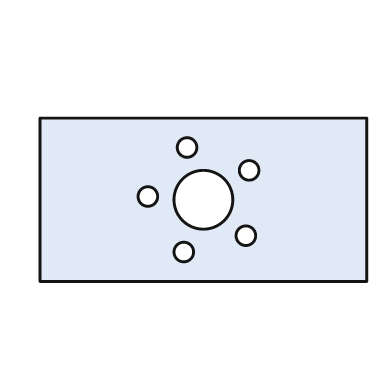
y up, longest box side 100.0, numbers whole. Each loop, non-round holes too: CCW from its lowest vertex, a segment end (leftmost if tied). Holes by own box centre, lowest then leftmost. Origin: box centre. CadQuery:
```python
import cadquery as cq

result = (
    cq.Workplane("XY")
    .moveTo(-50.0, -25.0)
    .lineTo(50.0, -25.0)
    .lineTo(50.0, 25.0)
    .lineTo(-50.0, 25.0)
    .close()
    .moveTo(-6.0, -16.0)
    .circle(3.0)
    .moveTo(13.0, -11.0)
    .circle(3.0)
    .moveTo(0.0, 0.0)
    .circle(9.0)
    .moveTo(-17.0, 1.0)
    .circle(3.0)
    .moveTo(14.0, 9.0)
    .circle(3.0)
    .moveTo(-5.0, 16.0)
    .circle(3.0)
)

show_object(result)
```